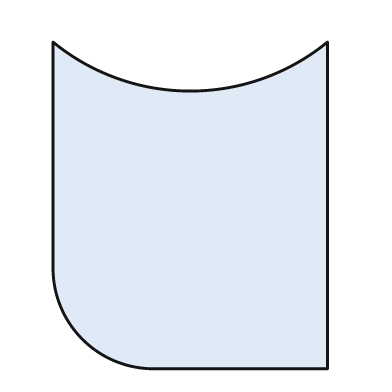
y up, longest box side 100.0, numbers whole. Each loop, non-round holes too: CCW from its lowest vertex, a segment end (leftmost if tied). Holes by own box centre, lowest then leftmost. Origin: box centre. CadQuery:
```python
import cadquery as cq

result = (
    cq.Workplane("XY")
    .moveTo(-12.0, -50.0)
    .lineTo(42.0, -50.0)
    .lineTo(42.0, 50.0)
    .threePointArc((0.0, 35.0), (-42.0, 50.0))
    .lineTo(-42.0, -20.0)
    .threePointArc((-33.0, -41.0), (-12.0, -50.0))
    .close()
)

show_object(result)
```